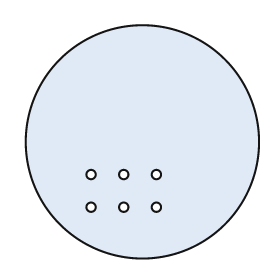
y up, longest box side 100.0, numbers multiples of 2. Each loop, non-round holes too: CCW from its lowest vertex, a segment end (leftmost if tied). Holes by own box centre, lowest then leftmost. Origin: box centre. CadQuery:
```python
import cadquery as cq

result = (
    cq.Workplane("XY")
    .moveTo(0.0, 0.0)
    .circle(50.0)
    .moveTo(-22.0, -28.0)
    .circle(2.0)
    .moveTo(-8.0, -28.0)
    .circle(2.0)
    .moveTo(6.0, -28.0)
    .circle(2.0)
    .moveTo(-22.0, -14.0)
    .circle(2.0)
    .moveTo(-8.0, -14.0)
    .circle(2.0)
    .moveTo(6.0, -14.0)
    .circle(2.0)
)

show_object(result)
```